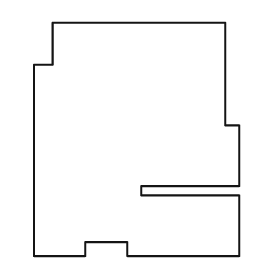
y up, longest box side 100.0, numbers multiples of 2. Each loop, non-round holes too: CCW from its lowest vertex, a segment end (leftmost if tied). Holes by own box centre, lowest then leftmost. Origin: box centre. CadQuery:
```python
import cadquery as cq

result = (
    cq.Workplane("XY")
    .moveTo(-44.0, -50.0)
    .lineTo(-22.0, -50.0)
    .lineTo(-22.0, -44.0)
    .lineTo(-4.0, -44.0)
    .lineTo(-4.0, -50.0)
    .lineTo(44.0, -50.0)
    .lineTo(44.0, -24.0)
    .lineTo(2.0, -24.0)
    .lineTo(2.0, -20.0)
    .lineTo(44.0, -20.0)
    .lineTo(44.0, 6.0)
    .lineTo(38.0, 6.0)
    .lineTo(38.0, 50.0)
    .lineTo(-36.0, 50.0)
    .lineTo(-36.0, 32.0)
    .lineTo(-44.0, 32.0)
    .close()
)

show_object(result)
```